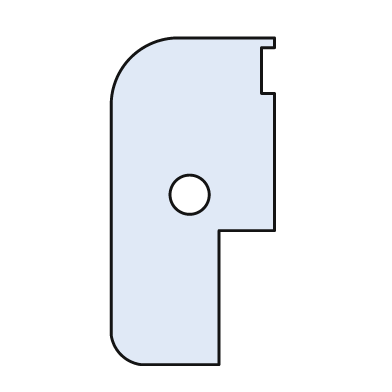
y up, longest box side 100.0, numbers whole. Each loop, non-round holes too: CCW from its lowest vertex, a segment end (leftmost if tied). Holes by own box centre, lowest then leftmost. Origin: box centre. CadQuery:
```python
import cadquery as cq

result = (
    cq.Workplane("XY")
    .moveTo(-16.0, -50.0)
    .lineTo(8.0, -50.0)
    .lineTo(8.0, -9.0)
    .lineTo(25.0, -9.0)
    .lineTo(25.0, 33.0)
    .lineTo(21.0, 33.0)
    .lineTo(21.0, 47.0)
    .lineTo(25.0, 47.0)
    .lineTo(25.0, 50.0)
    .lineTo(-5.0, 50.0)
    .threePointArc((-19.0, 44.0), (-25.0, 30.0))
    .lineTo(-25.0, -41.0)
    .threePointArc((-22.0, -47.0), (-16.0, -50.0))
    .close()
    .moveTo(-1.0, 2.0)
    .circle(6.0)
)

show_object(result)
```